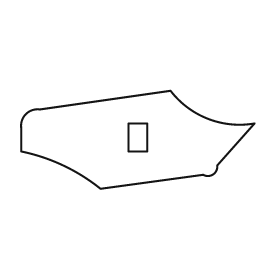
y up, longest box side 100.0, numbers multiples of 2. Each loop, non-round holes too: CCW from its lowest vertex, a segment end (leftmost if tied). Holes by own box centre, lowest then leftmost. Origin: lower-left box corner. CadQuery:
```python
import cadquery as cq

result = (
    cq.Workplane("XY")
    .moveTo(34.0, 0.0)
    .lineTo(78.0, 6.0)
    .threePointArc((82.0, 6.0), (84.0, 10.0))
    .lineTo(100.0, 28.0)
    .threePointArc((80.0, 30.0), (64.0, 42.0))
    .lineTo(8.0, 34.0)
    .threePointArc((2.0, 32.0), (0.0, 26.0))
    .lineTo(0.0, 16.0)
    .threePointArc((18.0, 10.0), (34.0, 0.0))
    .close()
    .moveTo(46.0, 16.0)
    .lineTo(54.0, 16.0)
    .lineTo(54.0, 28.0)
    .lineTo(46.0, 28.0)
    .close()
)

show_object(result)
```